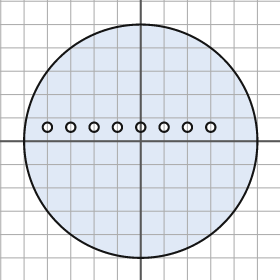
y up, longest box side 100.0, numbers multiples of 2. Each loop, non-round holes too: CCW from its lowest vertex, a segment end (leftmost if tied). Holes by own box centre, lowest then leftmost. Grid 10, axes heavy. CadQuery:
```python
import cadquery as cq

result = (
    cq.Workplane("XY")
    .moveTo(0.0, 0.0)
    .circle(50.0)
    .moveTo(-40.0, 6.0)
    .circle(2.0)
    .moveTo(-30.0, 6.0)
    .circle(2.0)
    .moveTo(-20.0, 6.0)
    .circle(2.0)
    .moveTo(-10.0, 6.0)
    .circle(2.0)
    .moveTo(0.0, 6.0)
    .circle(2.0)
    .moveTo(10.0, 6.0)
    .circle(2.0)
    .moveTo(20.0, 6.0)
    .circle(2.0)
    .moveTo(30.0, 6.0)
    .circle(2.0)
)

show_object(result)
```